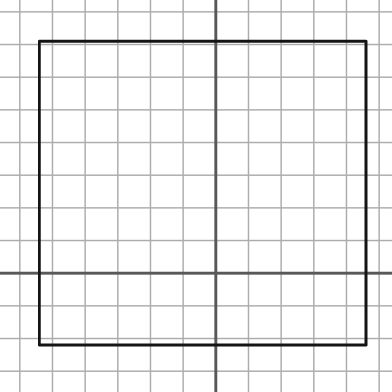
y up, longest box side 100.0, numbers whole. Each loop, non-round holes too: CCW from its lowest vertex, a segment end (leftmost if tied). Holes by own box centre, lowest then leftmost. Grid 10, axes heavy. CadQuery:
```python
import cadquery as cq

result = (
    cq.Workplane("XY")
    .moveTo(-54.0, -22.0)
    .lineTo(46.0, -22.0)
    .lineTo(46.0, 71.0)
    .lineTo(-54.0, 71.0)
    .close()
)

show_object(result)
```